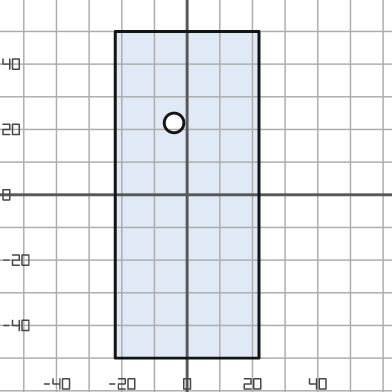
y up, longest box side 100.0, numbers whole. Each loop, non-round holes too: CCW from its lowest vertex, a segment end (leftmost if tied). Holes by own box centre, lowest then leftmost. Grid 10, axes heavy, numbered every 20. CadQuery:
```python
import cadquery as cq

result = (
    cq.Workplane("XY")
    .moveTo(-22.0, -50.0)
    .lineTo(22.0, -50.0)
    .lineTo(22.0, 50.0)
    .lineTo(-22.0, 50.0)
    .close()
    .moveTo(-4.0, 22.0)
    .circle(3.0)
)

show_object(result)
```